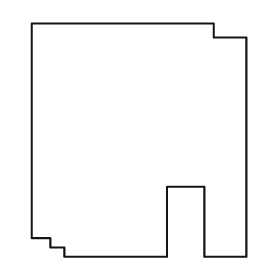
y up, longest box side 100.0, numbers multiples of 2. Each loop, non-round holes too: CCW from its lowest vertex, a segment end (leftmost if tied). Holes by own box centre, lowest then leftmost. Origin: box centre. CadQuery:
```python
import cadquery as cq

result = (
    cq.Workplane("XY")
    .moveTo(-32.0, -50.0)
    .lineTo(12.0, -50.0)
    .lineTo(12.0, -20.0)
    .lineTo(28.0, -20.0)
    .lineTo(28.0, -50.0)
    .lineTo(46.0, -50.0)
    .lineTo(46.0, 44.0)
    .lineTo(32.0, 44.0)
    .lineTo(32.0, 50.0)
    .lineTo(-46.0, 50.0)
    .lineTo(-46.0, -42.0)
    .lineTo(-38.0, -42.0)
    .lineTo(-38.0, -46.0)
    .lineTo(-32.0, -46.0)
    .close()
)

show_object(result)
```